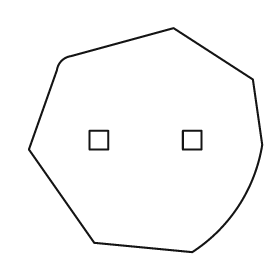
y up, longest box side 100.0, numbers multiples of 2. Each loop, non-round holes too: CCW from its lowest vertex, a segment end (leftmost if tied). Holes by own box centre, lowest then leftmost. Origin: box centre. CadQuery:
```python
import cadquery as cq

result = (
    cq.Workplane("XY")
    .moveTo(20.0, -48.0)
    .threePointArc((40.0, -28.0), (50.0, -2.0))
    .lineTo(46.0, 26.0)
    .lineTo(12.0, 48.0)
    .lineTo(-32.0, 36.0)
    .threePointArc((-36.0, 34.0), (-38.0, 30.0))
    .lineTo(-50.0, -4.0)
    .lineTo(-22.0, -44.0)
    .close()
    .moveTo(-24.0, -4.0)
    .lineTo(-16.0, -4.0)
    .lineTo(-16.0, 4.0)
    .lineTo(-24.0, 4.0)
    .close()
    .moveTo(16.0, -4.0)
    .lineTo(24.0, -4.0)
    .lineTo(24.0, 4.0)
    .lineTo(16.0, 4.0)
    .close()
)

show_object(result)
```